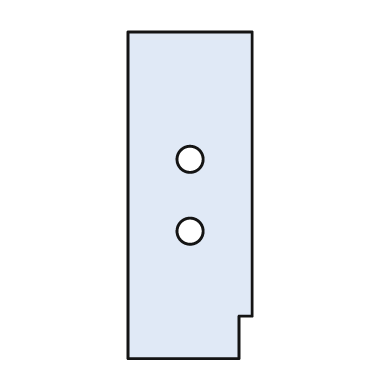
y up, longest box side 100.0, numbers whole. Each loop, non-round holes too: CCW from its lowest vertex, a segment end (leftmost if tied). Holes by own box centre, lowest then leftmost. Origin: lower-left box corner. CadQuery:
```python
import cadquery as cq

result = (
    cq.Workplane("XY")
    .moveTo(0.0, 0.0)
    .lineTo(34.0, 0.0)
    .lineTo(34.0, 13.0)
    .lineTo(38.0, 13.0)
    .lineTo(38.0, 100.0)
    .lineTo(0.0, 100.0)
    .close()
    .moveTo(19.0, 39.0)
    .circle(4.0)
    .moveTo(19.0, 61.0)
    .circle(4.0)
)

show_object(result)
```